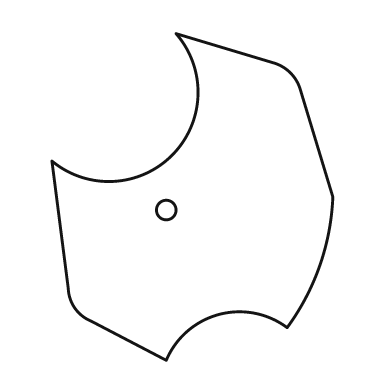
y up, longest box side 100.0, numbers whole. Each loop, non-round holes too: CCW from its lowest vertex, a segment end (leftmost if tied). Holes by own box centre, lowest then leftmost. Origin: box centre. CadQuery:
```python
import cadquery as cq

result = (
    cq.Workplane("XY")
    .moveTo(-8.0, -50.0)
    .threePointArc((8.0, -36.0), (29.0, -40.0))
    .threePointArc((39.0, -21.0), (43.0, 0.0))
    .lineTo(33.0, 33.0)
    .threePointArc((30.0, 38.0), (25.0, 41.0))
    .lineTo(-5.0, 50.0)
    .threePointArc((-6.0, 13.0), (-43.0, 11.0))
    .lineTo(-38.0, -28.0)
    .threePointArc((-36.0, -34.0), (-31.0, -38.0))
    .close()
    .moveTo(-8.0, -4.0)
    .circle(3.0)
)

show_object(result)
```